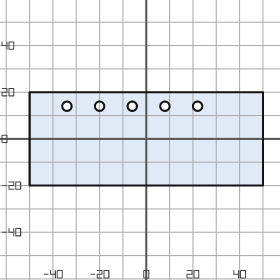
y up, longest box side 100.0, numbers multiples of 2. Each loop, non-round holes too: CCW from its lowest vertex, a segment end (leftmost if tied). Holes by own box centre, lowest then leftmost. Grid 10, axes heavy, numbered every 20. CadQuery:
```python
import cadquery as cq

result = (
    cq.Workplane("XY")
    .moveTo(-50.0, -20.0)
    .lineTo(50.0, -20.0)
    .lineTo(50.0, 20.0)
    .lineTo(-50.0, 20.0)
    .close()
    .moveTo(-34.0, 14.0)
    .circle(2.0)
    .moveTo(-20.0, 14.0)
    .circle(2.0)
    .moveTo(-6.0, 14.0)
    .circle(2.0)
    .moveTo(8.0, 14.0)
    .circle(2.0)
    .moveTo(22.0, 14.0)
    .circle(2.0)
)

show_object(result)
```